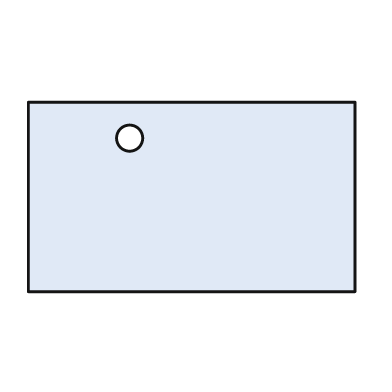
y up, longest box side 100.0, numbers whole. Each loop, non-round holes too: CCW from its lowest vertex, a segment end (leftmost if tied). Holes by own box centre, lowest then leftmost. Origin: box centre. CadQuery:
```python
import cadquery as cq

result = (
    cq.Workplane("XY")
    .moveTo(-50.0, -29.0)
    .lineTo(50.0, -29.0)
    .lineTo(50.0, 29.0)
    .lineTo(-50.0, 29.0)
    .close()
    .moveTo(-19.0, 18.0)
    .circle(4.0)
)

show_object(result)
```